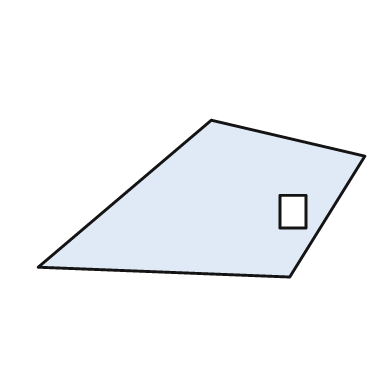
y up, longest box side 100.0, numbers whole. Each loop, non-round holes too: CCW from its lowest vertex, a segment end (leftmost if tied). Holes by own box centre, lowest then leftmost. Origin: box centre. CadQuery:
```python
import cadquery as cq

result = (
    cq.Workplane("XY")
    .moveTo(27.0, -24.0)
    .lineTo(50.0, 13.0)
    .lineTo(3.0, 24.0)
    .lineTo(-50.0, -21.0)
    .close()
    .moveTo(24.0, -9.0)
    .lineTo(32.0, -9.0)
    .lineTo(32.0, 1.0)
    .lineTo(24.0, 1.0)
    .close()
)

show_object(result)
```